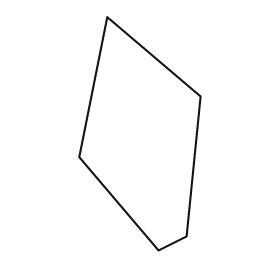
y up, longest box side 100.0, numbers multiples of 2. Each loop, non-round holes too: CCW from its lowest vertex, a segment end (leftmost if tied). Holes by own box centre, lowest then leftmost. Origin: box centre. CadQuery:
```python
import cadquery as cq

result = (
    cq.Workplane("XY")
    .moveTo(8.0, -50.0)
    .lineTo(20.0, -44.0)
    .lineTo(26.0, 16.0)
    .lineTo(-14.0, 50.0)
    .lineTo(-26.0, -10.0)
    .close()
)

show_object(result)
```